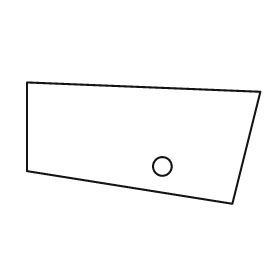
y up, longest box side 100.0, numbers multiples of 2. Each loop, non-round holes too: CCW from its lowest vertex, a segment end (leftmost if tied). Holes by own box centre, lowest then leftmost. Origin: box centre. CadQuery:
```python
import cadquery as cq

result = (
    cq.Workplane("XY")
    .moveTo(38.0, -26.0)
    .lineTo(50.0, 22.0)
    .lineTo(-50.0, 26.0)
    .lineTo(-50.0, -12.0)
    .close()
    .moveTo(8.0, -10.0)
    .circle(4.0)
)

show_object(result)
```